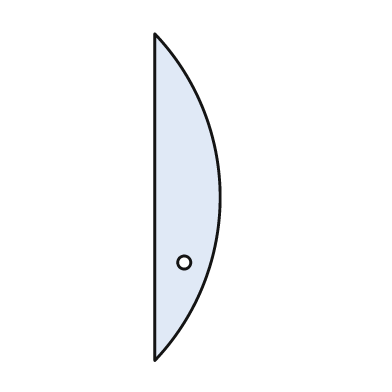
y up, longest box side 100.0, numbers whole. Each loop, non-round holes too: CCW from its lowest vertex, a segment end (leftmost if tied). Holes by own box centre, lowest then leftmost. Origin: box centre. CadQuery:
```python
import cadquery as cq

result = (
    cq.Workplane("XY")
    .moveTo(-10.0, -50.0)
    .threePointArc((10.0, 0.0), (-10.0, 50.0))
    .close()
    .moveTo(-1.0, -20.0)
    .circle(2.0)
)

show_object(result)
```